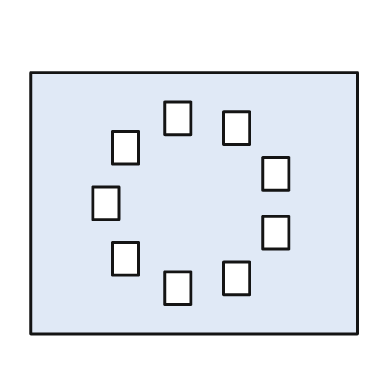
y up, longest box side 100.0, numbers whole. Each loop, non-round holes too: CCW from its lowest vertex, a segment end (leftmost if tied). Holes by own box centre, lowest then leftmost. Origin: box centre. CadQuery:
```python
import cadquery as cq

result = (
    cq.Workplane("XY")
    .moveTo(-50.0, -40.0)
    .lineTo(50.0, -40.0)
    .lineTo(50.0, 40.0)
    .lineTo(-50.0, 40.0)
    .close()
    .moveTo(-9.0, -31.0)
    .lineTo(-1.0, -31.0)
    .lineTo(-1.0, -21.0)
    .lineTo(-9.0, -21.0)
    .close()
    .moveTo(9.0, -28.0)
    .lineTo(17.0, -28.0)
    .lineTo(17.0, -18.0)
    .lineTo(9.0, -18.0)
    .close()
    .moveTo(-25.0, -22.0)
    .lineTo(-17.0, -22.0)
    .lineTo(-17.0, -12.0)
    .lineTo(-25.0, -12.0)
    .close()
    .moveTo(21.0, -14.0)
    .lineTo(29.0, -14.0)
    .lineTo(29.0, -4.0)
    .lineTo(21.0, -4.0)
    .close()
    .moveTo(-31.0, -5.0)
    .lineTo(-23.0, -5.0)
    .lineTo(-23.0, 5.0)
    .lineTo(-31.0, 5.0)
    .close()
    .moveTo(21.0, 4.0)
    .lineTo(29.0, 4.0)
    .lineTo(29.0, 14.0)
    .lineTo(21.0, 14.0)
    .close()
    .moveTo(-25.0, 12.0)
    .lineTo(-17.0, 12.0)
    .lineTo(-17.0, 22.0)
    .lineTo(-25.0, 22.0)
    .close()
    .moveTo(9.0, 18.0)
    .lineTo(17.0, 18.0)
    .lineTo(17.0, 28.0)
    .lineTo(9.0, 28.0)
    .close()
    .moveTo(-9.0, 21.0)
    .lineTo(-1.0, 21.0)
    .lineTo(-1.0, 31.0)
    .lineTo(-9.0, 31.0)
    .close()
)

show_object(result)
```